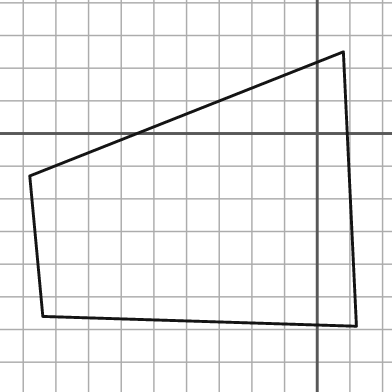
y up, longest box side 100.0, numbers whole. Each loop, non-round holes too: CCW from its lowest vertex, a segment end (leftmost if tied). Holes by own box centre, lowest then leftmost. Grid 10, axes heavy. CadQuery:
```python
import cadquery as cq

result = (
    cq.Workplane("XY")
    .moveTo(12.0, -59.0)
    .lineTo(8.0, 25.0)
    .lineTo(-88.0, -13.0)
    .lineTo(-84.0, -56.0)
    .close()
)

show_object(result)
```